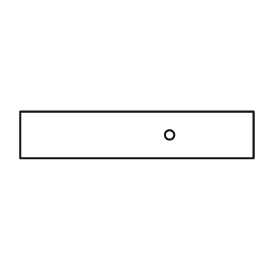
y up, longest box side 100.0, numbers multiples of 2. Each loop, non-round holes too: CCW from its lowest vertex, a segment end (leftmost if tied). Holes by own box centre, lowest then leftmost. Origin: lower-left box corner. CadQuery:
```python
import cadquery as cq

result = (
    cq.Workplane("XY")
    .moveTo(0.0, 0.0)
    .lineTo(100.0, 0.0)
    .lineTo(100.0, 20.0)
    .lineTo(0.0, 20.0)
    .close()
    .moveTo(64.0, 10.0)
    .circle(2.0)
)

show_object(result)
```